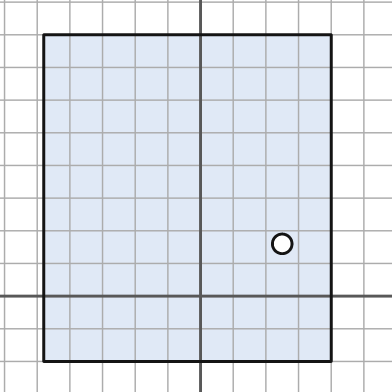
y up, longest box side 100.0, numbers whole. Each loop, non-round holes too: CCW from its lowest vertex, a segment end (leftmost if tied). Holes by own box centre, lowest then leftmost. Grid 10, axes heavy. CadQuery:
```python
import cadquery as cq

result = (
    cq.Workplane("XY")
    .moveTo(-48.0, -20.0)
    .lineTo(40.0, -20.0)
    .lineTo(40.0, 80.0)
    .lineTo(-48.0, 80.0)
    .close()
    .moveTo(25.0, 16.0)
    .circle(3.0)
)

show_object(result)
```